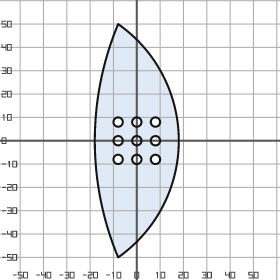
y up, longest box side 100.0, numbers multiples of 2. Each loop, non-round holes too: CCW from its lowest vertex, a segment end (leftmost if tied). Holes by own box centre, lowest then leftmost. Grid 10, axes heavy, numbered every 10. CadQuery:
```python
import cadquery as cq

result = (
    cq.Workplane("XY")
    .moveTo(-8.0, -50.0)
    .threePointArc((18.0, 0.0), (-8.0, 50.0))
    .threePointArc((-18.0, 0.0), (-8.0, -50.0))
    .close()
    .moveTo(-8.0, -8.0)
    .circle(2.0)
    .moveTo(0.0, -8.0)
    .circle(2.0)
    .moveTo(8.0, -8.0)
    .circle(2.0)
    .moveTo(-8.0, 0.0)
    .circle(2.0)
    .moveTo(0.0, 0.0)
    .circle(2.0)
    .moveTo(8.0, 0.0)
    .circle(2.0)
    .moveTo(-8.0, 8.0)
    .circle(2.0)
    .moveTo(0.0, 8.0)
    .circle(2.0)
    .moveTo(8.0, 8.0)
    .circle(2.0)
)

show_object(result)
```